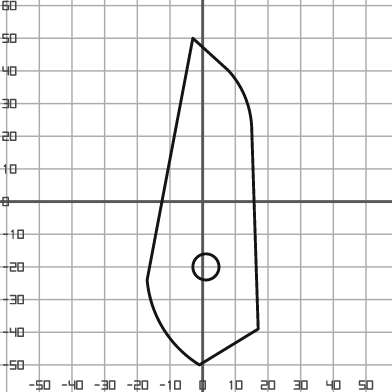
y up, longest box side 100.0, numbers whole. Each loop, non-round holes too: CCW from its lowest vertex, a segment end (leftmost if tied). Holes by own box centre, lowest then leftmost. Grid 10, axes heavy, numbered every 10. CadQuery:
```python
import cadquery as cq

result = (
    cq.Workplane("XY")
    .moveTo(-1.0, -50.0)
    .lineTo(17.0, -39.0)
    .lineTo(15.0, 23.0)
    .threePointArc((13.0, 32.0), (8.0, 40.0))
    .lineTo(-3.0, 50.0)
    .lineTo(-17.0, -24.0)
    .threePointArc((-12.0, -39.0), (-1.0, -50.0))
    .close()
    .moveTo(1.0, -20.0)
    .circle(4.0)
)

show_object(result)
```